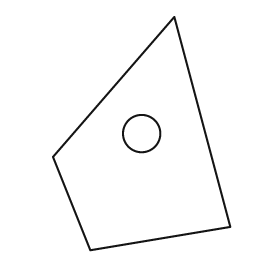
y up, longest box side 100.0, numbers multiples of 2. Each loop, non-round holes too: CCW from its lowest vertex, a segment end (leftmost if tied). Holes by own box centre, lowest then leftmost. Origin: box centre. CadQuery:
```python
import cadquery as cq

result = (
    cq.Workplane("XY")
    .moveTo(-22.0, -50.0)
    .lineTo(38.0, -40.0)
    .lineTo(14.0, 50.0)
    .lineTo(-38.0, -10.0)
    .close()
    .moveTo(0.0, 0.0)
    .circle(8.0)
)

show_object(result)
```